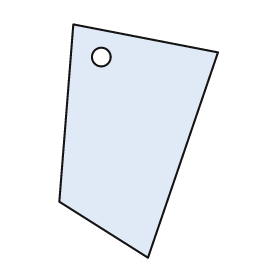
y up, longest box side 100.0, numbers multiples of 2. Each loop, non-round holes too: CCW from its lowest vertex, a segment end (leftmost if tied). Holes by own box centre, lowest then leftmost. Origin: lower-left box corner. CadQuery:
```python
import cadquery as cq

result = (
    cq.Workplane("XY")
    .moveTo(38.0, 0.0)
    .lineTo(68.0, 88.0)
    .lineTo(6.0, 100.0)
    .lineTo(0.0, 24.0)
    .close()
    .moveTo(18.0, 86.0)
    .circle(4.0)
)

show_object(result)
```